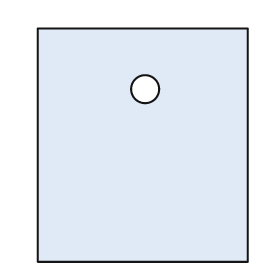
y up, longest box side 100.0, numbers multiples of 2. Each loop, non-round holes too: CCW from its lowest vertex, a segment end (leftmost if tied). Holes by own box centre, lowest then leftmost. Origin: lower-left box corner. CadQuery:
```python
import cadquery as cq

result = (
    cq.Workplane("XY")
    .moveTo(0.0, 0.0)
    .lineTo(90.0, 0.0)
    .lineTo(90.0, 100.0)
    .lineTo(0.0, 100.0)
    .close()
    .moveTo(46.0, 74.0)
    .circle(6.0)
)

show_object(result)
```